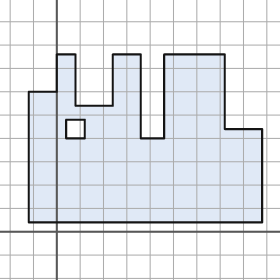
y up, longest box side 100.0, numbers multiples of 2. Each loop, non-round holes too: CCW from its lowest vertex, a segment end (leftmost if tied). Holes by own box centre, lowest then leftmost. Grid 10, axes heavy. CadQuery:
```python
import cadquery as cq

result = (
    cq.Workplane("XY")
    .moveTo(-12.0, 4.0)
    .lineTo(88.0, 4.0)
    .lineTo(88.0, 44.0)
    .lineTo(72.0, 44.0)
    .lineTo(72.0, 76.0)
    .lineTo(46.0, 76.0)
    .lineTo(46.0, 40.0)
    .lineTo(36.0, 40.0)
    .lineTo(36.0, 76.0)
    .lineTo(24.0, 76.0)
    .lineTo(24.0, 54.0)
    .lineTo(8.0, 54.0)
    .lineTo(8.0, 76.0)
    .lineTo(0.0, 76.0)
    .lineTo(0.0, 60.0)
    .lineTo(-12.0, 60.0)
    .close()
    .moveTo(4.0, 40.0)
    .lineTo(12.0, 40.0)
    .lineTo(12.0, 48.0)
    .lineTo(4.0, 48.0)
    .close()
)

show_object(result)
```